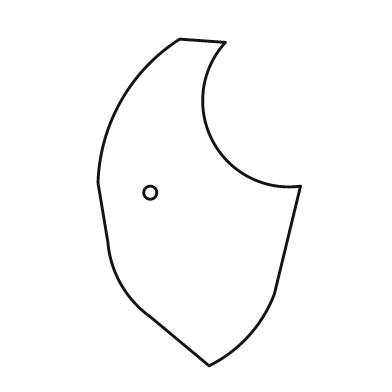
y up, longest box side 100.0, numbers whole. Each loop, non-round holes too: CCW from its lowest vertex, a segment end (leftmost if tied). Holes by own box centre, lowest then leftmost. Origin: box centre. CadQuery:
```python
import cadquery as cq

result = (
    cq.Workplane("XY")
    .moveTo(3.0, -50.0)
    .threePointArc((15.0, -41.0), (23.0, -28.0))
    .lineTo(31.0, 5.0)
    .threePointArc((4.0, 19.0), (8.0, 49.0))
    .lineTo(-6.0, 50.0)
    .threePointArc((-24.0, 31.0), (-31.0, 6.0))
    .lineTo(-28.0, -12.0)
    .threePointArc((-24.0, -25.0), (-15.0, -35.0))
    .close()
    .moveTo(-15.0, 3.0)
    .circle(2.0)
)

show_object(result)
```